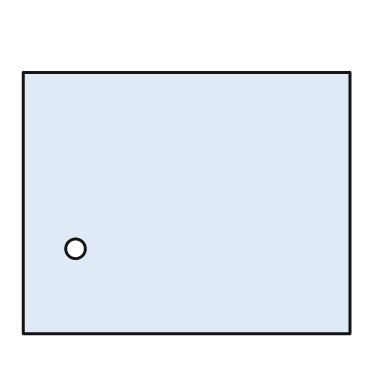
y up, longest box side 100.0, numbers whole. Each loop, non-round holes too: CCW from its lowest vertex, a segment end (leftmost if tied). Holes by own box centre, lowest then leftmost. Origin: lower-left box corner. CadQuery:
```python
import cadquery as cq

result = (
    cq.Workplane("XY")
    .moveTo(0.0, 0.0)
    .lineTo(100.0, 0.0)
    .lineTo(100.0, 80.0)
    .lineTo(0.0, 80.0)
    .close()
    .moveTo(16.0, 26.0)
    .circle(3.0)
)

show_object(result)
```